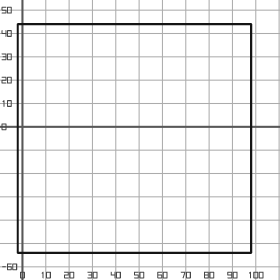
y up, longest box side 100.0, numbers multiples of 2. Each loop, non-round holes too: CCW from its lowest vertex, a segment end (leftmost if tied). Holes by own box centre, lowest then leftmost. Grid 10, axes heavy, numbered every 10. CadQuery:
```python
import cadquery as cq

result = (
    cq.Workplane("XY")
    .moveTo(-2.0, -54.0)
    .lineTo(98.0, -54.0)
    .lineTo(98.0, 44.0)
    .lineTo(-2.0, 44.0)
    .close()
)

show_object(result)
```